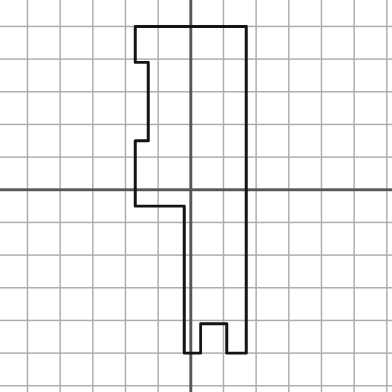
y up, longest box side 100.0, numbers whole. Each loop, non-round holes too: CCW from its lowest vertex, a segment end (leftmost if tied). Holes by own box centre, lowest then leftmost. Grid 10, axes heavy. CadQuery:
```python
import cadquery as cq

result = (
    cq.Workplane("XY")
    .moveTo(-2.0, -50.0)
    .lineTo(3.0, -50.0)
    .lineTo(3.0, -41.0)
    .lineTo(11.0, -41.0)
    .lineTo(11.0, -50.0)
    .lineTo(17.0, -50.0)
    .lineTo(17.0, 50.0)
    .lineTo(-17.0, 50.0)
    .lineTo(-17.0, 39.0)
    .lineTo(-13.0, 39.0)
    .lineTo(-13.0, 15.0)
    .lineTo(-17.0, 15.0)
    .lineTo(-17.0, -5.0)
    .lineTo(-2.0, -5.0)
    .close()
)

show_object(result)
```